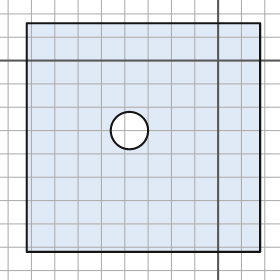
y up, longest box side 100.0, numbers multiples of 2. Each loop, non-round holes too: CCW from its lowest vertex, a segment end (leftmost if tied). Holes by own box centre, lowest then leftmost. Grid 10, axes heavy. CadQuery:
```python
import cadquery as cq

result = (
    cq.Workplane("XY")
    .moveTo(-82.0, -82.0)
    .lineTo(18.0, -82.0)
    .lineTo(18.0, 16.0)
    .lineTo(-82.0, 16.0)
    .close()
    .moveTo(-38.0, -30.0)
    .circle(8.0)
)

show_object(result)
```